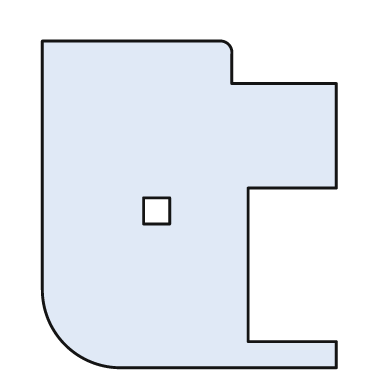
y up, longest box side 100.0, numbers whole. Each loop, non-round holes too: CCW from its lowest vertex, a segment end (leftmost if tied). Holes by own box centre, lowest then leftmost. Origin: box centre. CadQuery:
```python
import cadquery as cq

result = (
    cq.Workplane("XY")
    .moveTo(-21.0, -50.0)
    .lineTo(45.0, -50.0)
    .lineTo(45.0, -42.0)
    .lineTo(18.0, -42.0)
    .lineTo(18.0, 5.0)
    .lineTo(45.0, 5.0)
    .lineTo(45.0, 37.0)
    .lineTo(13.0, 37.0)
    .lineTo(13.0, 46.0)
    .threePointArc((12.0, 49.0), (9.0, 50.0))
    .lineTo(-45.0, 50.0)
    .lineTo(-45.0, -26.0)
    .threePointArc((-38.0, -43.0), (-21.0, -50.0))
    .close()
    .moveTo(-14.0, -6.0)
    .lineTo(-6.0, -6.0)
    .lineTo(-6.0, 2.0)
    .lineTo(-14.0, 2.0)
    .close()
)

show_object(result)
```